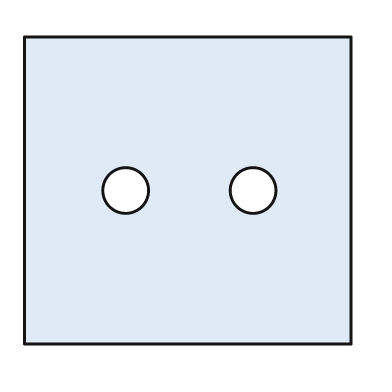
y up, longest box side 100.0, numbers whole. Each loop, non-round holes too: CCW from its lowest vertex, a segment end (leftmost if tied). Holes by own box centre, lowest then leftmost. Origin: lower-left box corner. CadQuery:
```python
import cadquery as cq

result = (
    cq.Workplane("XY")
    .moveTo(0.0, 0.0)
    .lineTo(100.0, 0.0)
    .lineTo(100.0, 94.0)
    .lineTo(0.0, 94.0)
    .close()
    .moveTo(31.0, 47.0)
    .circle(7.0)
    .moveTo(70.0, 47.0)
    .circle(7.0)
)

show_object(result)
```